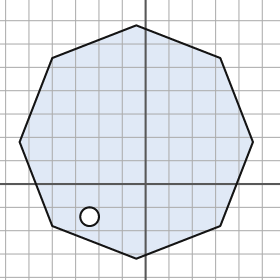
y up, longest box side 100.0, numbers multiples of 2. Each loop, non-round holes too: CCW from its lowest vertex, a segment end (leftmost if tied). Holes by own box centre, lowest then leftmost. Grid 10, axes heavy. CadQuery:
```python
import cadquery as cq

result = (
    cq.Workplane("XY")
    .moveTo(-4.0, -32.0)
    .lineTo(32.0, -18.0)
    .lineTo(46.0, 18.0)
    .lineTo(32.0, 54.0)
    .lineTo(-4.0, 68.0)
    .lineTo(-40.0, 54.0)
    .lineTo(-54.0, 18.0)
    .lineTo(-40.0, -18.0)
    .close()
    .moveTo(-24.0, -14.0)
    .circle(4.0)
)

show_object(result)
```